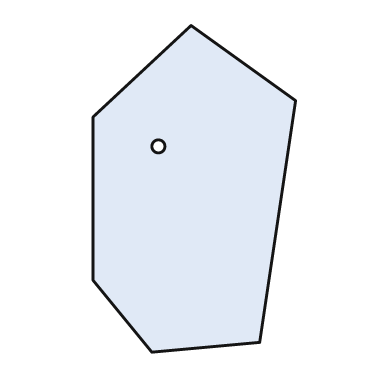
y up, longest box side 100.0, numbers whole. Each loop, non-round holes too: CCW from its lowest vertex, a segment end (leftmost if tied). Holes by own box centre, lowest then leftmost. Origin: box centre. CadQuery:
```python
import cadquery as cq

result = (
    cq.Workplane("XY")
    .moveTo(-13.0, -50.0)
    .lineTo(20.0, -47.0)
    .lineTo(31.0, 27.0)
    .lineTo(-1.0, 50.0)
    .lineTo(-31.0, 22.0)
    .lineTo(-31.0, -28.0)
    .close()
    .moveTo(-11.0, 13.0)
    .circle(2.0)
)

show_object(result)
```